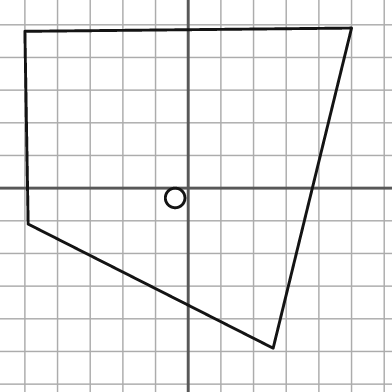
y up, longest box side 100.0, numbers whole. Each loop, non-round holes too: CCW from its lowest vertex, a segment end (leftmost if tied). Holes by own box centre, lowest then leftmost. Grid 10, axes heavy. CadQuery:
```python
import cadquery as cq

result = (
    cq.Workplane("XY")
    .moveTo(26.0, -49.0)
    .lineTo(50.0, 49.0)
    .lineTo(-50.0, 48.0)
    .lineTo(-49.0, -11.0)
    .close()
    .moveTo(-4.0, -3.0)
    .circle(3.0)
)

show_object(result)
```